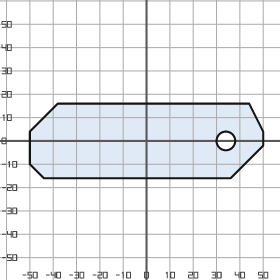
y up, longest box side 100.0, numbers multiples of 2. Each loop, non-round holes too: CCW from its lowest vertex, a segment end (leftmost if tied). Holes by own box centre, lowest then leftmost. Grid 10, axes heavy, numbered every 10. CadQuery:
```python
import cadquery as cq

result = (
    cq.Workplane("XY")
    .moveTo(-44.0, -16.0)
    .lineTo(36.0, -16.0)
    .lineTo(50.0, -2.0)
    .lineTo(50.0, 4.0)
    .lineTo(44.0, 16.0)
    .lineTo(-38.0, 16.0)
    .lineTo(-50.0, 4.0)
    .lineTo(-50.0, -10.0)
    .close()
    .moveTo(34.0, 0.0)
    .circle(4.0)
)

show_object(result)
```